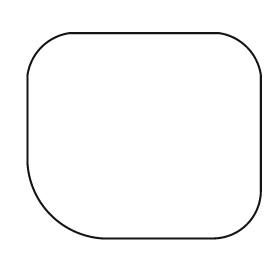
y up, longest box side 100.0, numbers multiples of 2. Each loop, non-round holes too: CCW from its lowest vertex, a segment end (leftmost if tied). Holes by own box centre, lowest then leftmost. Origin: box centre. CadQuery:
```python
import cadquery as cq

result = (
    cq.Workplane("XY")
    .moveTo(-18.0, -44.0)
    .lineTo(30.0, -44.0)
    .threePointArc((44.0, -38.0), (50.0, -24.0))
    .lineTo(50.0, 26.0)
    .threePointArc((44.0, 38.0), (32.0, 44.0))
    .lineTo(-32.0, 44.0)
    .threePointArc((-44.0, 38.0), (-50.0, 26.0))
    .lineTo(-50.0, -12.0)
    .threePointArc((-40.0, -34.0), (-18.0, -44.0))
    .close()
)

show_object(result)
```